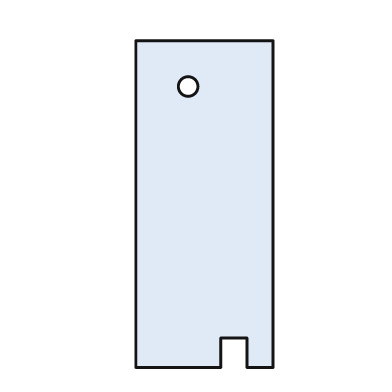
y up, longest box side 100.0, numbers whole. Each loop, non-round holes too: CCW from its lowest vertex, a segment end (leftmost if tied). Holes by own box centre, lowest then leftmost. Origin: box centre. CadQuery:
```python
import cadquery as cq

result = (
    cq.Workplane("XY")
    .moveTo(-21.0, -50.0)
    .lineTo(5.0, -50.0)
    .lineTo(5.0, -41.0)
    .lineTo(13.0, -41.0)
    .lineTo(13.0, -50.0)
    .lineTo(21.0, -50.0)
    .lineTo(21.0, 50.0)
    .lineTo(-21.0, 50.0)
    .close()
    .moveTo(-5.0, 36.0)
    .circle(3.0)
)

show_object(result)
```